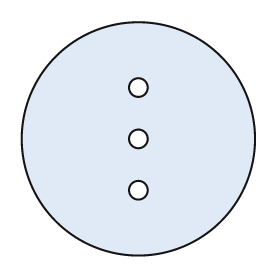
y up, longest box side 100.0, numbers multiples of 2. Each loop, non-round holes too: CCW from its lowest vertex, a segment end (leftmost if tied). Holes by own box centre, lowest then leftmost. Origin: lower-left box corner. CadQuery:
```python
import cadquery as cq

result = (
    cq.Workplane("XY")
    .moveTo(50.0, 50.0)
    .circle(50.0)
    .moveTo(50.0, 28.0)
    .circle(4.0)
    .moveTo(50.0, 50.0)
    .circle(4.0)
    .moveTo(50.0, 72.0)
    .circle(4.0)
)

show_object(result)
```